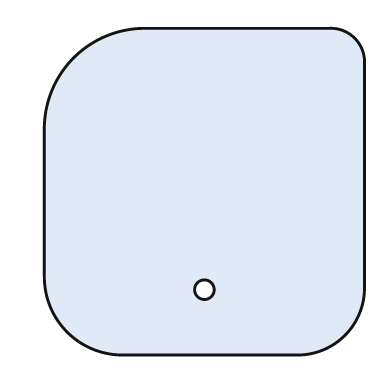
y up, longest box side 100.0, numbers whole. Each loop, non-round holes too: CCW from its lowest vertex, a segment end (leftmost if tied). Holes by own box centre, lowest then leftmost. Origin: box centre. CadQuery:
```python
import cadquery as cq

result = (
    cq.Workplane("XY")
    .moveTo(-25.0, -50.0)
    .lineTo(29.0, -50.0)
    .threePointArc((43.0, -44.0), (49.0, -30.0))
    .lineTo(49.0, 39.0)
    .threePointArc((46.0, 47.0), (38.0, 50.0))
    .lineTo(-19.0, 50.0)
    .threePointArc((-40.0, 41.0), (-49.0, 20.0))
    .lineTo(-49.0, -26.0)
    .threePointArc((-42.0, -43.0), (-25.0, -50.0))
    .close()
    .moveTo(0.0, -30.0)
    .circle(3.0)
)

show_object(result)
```